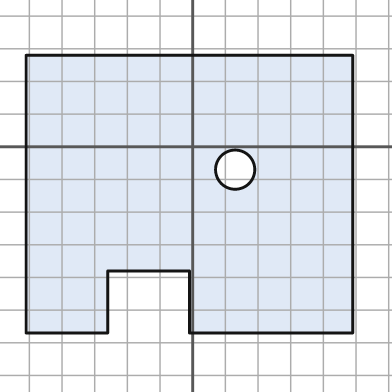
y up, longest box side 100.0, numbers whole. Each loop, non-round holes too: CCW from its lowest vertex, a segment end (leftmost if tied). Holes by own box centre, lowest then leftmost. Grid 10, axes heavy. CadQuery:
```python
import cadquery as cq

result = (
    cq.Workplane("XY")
    .moveTo(-51.0, -57.0)
    .lineTo(-26.0, -57.0)
    .lineTo(-26.0, -38.0)
    .lineTo(-1.0, -38.0)
    .lineTo(-1.0, -57.0)
    .lineTo(49.0, -57.0)
    .lineTo(49.0, 28.0)
    .lineTo(-51.0, 28.0)
    .close()
    .moveTo(13.0, -7.0)
    .circle(6.0)
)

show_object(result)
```